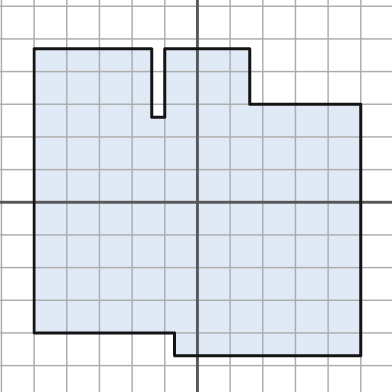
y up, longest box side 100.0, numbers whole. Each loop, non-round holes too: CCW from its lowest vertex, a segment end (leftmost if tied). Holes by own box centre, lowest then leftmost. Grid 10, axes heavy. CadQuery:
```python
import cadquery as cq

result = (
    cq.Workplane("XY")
    .moveTo(-7.0, -47.0)
    .lineTo(50.0, -47.0)
    .lineTo(50.0, 30.0)
    .lineTo(16.0, 30.0)
    .lineTo(16.0, 47.0)
    .lineTo(-10.0, 47.0)
    .lineTo(-10.0, 26.0)
    .lineTo(-14.0, 26.0)
    .lineTo(-14.0, 47.0)
    .lineTo(-50.0, 47.0)
    .lineTo(-50.0, -40.0)
    .lineTo(-7.0, -40.0)
    .close()
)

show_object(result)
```